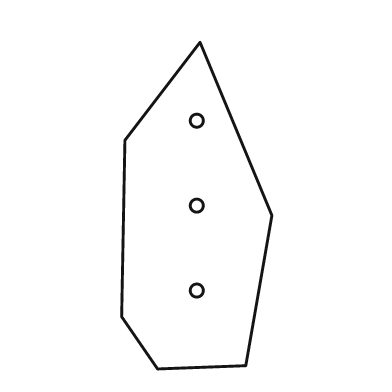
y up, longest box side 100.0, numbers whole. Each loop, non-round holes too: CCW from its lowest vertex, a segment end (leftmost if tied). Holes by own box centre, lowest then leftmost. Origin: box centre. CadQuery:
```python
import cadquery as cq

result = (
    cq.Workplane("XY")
    .moveTo(-12.0, -50.0)
    .lineTo(15.0, -49.0)
    .lineTo(23.0, -3.0)
    .lineTo(1.0, 50.0)
    .lineTo(-22.0, 20.0)
    .lineTo(-23.0, -34.0)
    .close()
    .moveTo(0.0, -26.0)
    .circle(2.0)
    .moveTo(0.0, 0.0)
    .circle(2.0)
    .moveTo(0.0, 26.0)
    .circle(2.0)
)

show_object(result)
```